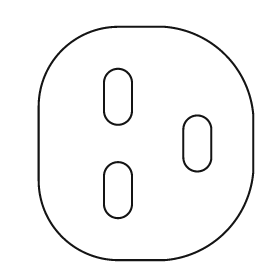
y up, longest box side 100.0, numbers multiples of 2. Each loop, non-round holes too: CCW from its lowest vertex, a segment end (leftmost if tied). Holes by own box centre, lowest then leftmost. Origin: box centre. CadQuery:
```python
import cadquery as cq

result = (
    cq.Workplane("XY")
    .moveTo(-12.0, -50.0)
    .lineTo(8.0, -50.0)
    .threePointArc((34.0, -38.0), (46.0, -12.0))
    .lineTo(46.0, 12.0)
    .threePointArc((34.0, 38.0), (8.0, 50.0))
    .lineTo(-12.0, 50.0)
    .threePointArc((-36.0, 40.0), (-46.0, 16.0))
    .lineTo(-46.0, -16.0)
    .threePointArc((-36.0, -40.0), (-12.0, -50.0))
    .close()
    .moveTo(-18.0, -26.0)
    .threePointArc((-12.0, -32.0), (-6.0, -26.0))
    .lineTo(-6.0, -14.0)
    .threePointArc((-12.0, -8.0), (-18.0, -14.0))
    .close()
    .moveTo(16.0, -6.0)
    .threePointArc((22.0, -12.0), (28.0, -6.0))
    .lineTo(28.0, 6.0)
    .threePointArc((22.0, 12.0), (16.0, 6.0))
    .close()
    .moveTo(-18.0, 14.0)
    .threePointArc((-12.0, 8.0), (-6.0, 14.0))
    .lineTo(-6.0, 26.0)
    .threePointArc((-12.0, 32.0), (-18.0, 26.0))
    .close()
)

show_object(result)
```